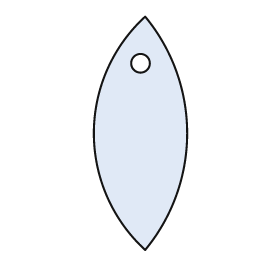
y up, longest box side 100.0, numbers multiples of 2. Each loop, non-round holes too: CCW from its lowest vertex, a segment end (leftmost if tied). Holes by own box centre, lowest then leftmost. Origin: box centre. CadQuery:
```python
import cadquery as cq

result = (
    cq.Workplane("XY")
    .moveTo(2.0, -50.0)
    .threePointArc((20.0, 0.0), (2.0, 50.0))
    .threePointArc((-20.0, 0.0), (2.0, -50.0))
    .close()
    .moveTo(0.0, 30.0)
    .circle(4.0)
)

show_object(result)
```